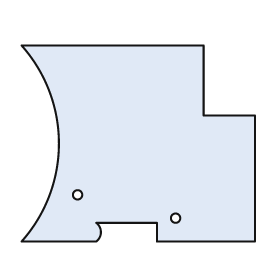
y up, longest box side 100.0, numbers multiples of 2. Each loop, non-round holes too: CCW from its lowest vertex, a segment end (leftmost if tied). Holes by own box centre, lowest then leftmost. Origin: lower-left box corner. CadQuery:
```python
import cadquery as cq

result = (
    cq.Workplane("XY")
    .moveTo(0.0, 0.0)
    .lineTo(32.0, 0.0)
    .threePointArc((34.0, 4.0), (32.0, 8.0))
    .lineTo(58.0, 8.0)
    .lineTo(58.0, 0.0)
    .lineTo(100.0, 0.0)
    .lineTo(100.0, 54.0)
    .lineTo(78.0, 54.0)
    .lineTo(78.0, 84.0)
    .lineTo(0.0, 84.0)
    .threePointArc((16.0, 42.0), (0.0, 0.0))
    .close()
    .moveTo(66.0, 10.0)
    .circle(2.0)
    .moveTo(24.0, 20.0)
    .circle(2.0)
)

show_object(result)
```